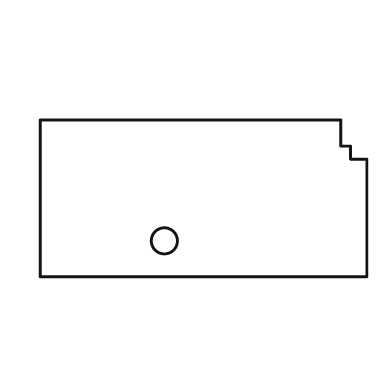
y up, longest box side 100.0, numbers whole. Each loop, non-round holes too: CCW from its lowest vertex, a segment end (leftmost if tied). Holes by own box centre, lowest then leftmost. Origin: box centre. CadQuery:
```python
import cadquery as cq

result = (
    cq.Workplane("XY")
    .moveTo(-50.0, -24.0)
    .lineTo(50.0, -24.0)
    .lineTo(50.0, 12.0)
    .lineTo(45.0, 12.0)
    .lineTo(45.0, 16.0)
    .lineTo(42.0, 16.0)
    .lineTo(42.0, 24.0)
    .lineTo(-50.0, 24.0)
    .close()
    .moveTo(-12.0, -13.0)
    .circle(4.0)
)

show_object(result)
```